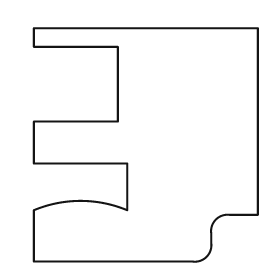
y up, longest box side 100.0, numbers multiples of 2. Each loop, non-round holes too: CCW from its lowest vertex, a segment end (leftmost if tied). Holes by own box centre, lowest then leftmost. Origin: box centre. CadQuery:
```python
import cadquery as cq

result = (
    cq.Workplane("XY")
    .moveTo(-48.0, -50.0)
    .lineTo(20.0, -50.0)
    .threePointArc((26.0, -48.0), (28.0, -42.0))
    .lineTo(28.0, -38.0)
    .threePointArc((30.0, -32.0), (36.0, -30.0))
    .lineTo(48.0, -30.0)
    .lineTo(48.0, 50.0)
    .lineTo(-48.0, 50.0)
    .lineTo(-48.0, 42.0)
    .lineTo(-12.0, 42.0)
    .lineTo(-12.0, 10.0)
    .lineTo(-48.0, 10.0)
    .lineTo(-48.0, -8.0)
    .lineTo(-8.0, -8.0)
    .lineTo(-8.0, -28.0)
    .threePointArc((-28.0, -24.0), (-48.0, -28.0))
    .close()
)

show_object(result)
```